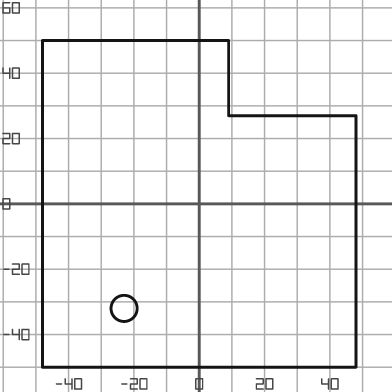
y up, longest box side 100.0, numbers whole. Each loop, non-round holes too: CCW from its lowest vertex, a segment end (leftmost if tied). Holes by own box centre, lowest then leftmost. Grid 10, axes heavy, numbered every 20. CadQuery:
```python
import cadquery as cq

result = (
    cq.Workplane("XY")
    .moveTo(-48.0, -50.0)
    .lineTo(48.0, -50.0)
    .lineTo(48.0, 27.0)
    .lineTo(9.0, 27.0)
    .lineTo(9.0, 50.0)
    .lineTo(-48.0, 50.0)
    .close()
    .moveTo(-23.0, -32.0)
    .circle(4.0)
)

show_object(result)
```